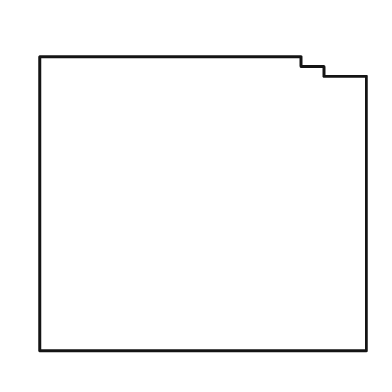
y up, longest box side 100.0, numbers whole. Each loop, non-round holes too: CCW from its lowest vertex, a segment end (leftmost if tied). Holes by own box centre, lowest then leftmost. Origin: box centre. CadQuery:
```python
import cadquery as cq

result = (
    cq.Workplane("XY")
    .moveTo(-50.0, -45.0)
    .lineTo(50.0, -45.0)
    .lineTo(50.0, 39.0)
    .lineTo(37.0, 39.0)
    .lineTo(37.0, 42.0)
    .lineTo(30.0, 42.0)
    .lineTo(30.0, 45.0)
    .lineTo(-50.0, 45.0)
    .close()
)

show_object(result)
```